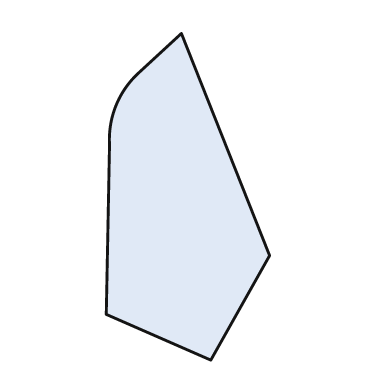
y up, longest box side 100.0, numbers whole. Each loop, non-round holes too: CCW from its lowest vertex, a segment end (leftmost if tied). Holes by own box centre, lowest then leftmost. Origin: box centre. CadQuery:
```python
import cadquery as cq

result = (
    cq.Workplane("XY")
    .moveTo(7.0, -50.0)
    .lineTo(25.0, -18.0)
    .lineTo(-2.0, 50.0)
    .lineTo(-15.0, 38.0)
    .threePointArc((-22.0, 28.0), (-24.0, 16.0))
    .lineTo(-25.0, -36.0)
    .close()
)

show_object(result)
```